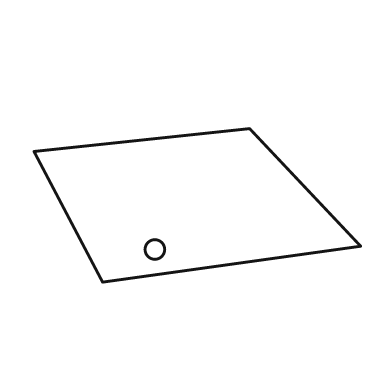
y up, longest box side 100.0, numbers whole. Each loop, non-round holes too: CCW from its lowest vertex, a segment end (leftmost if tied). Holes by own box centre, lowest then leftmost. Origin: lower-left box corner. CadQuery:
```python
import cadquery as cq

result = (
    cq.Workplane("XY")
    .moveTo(21.0, 0.0)
    .lineTo(100.0, 11.0)
    .lineTo(66.0, 47.0)
    .lineTo(0.0, 40.0)
    .close()
    .moveTo(37.0, 10.0)
    .circle(3.0)
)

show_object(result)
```